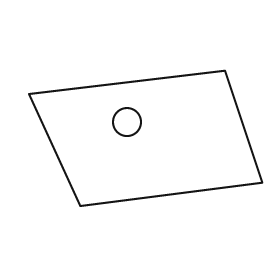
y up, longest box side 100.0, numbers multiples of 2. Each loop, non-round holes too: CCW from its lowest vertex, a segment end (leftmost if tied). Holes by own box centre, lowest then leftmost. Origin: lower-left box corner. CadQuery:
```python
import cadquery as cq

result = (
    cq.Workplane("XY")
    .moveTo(22.0, 0.0)
    .lineTo(100.0, 10.0)
    .lineTo(84.0, 58.0)
    .lineTo(0.0, 48.0)
    .close()
    .moveTo(42.0, 36.0)
    .circle(6.0)
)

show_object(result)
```